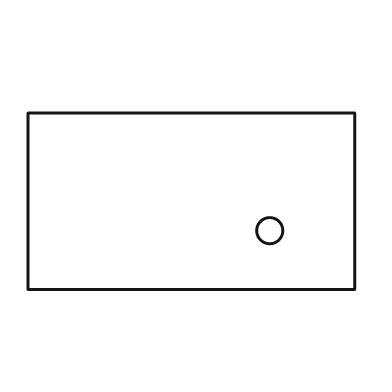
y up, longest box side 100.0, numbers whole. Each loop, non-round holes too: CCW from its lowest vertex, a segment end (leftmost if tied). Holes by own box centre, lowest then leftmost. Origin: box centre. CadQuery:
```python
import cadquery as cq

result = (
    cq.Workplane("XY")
    .moveTo(-50.0, -27.0)
    .lineTo(50.0, -27.0)
    .lineTo(50.0, 27.0)
    .lineTo(-50.0, 27.0)
    .close()
    .moveTo(24.0, -9.0)
    .circle(4.0)
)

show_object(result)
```